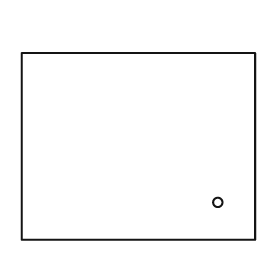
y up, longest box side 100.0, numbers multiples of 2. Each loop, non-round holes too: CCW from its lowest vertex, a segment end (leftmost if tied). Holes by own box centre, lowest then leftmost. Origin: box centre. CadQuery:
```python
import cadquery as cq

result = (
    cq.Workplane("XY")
    .moveTo(-50.0, -40.0)
    .lineTo(50.0, -40.0)
    .lineTo(50.0, 40.0)
    .lineTo(-50.0, 40.0)
    .close()
    .moveTo(34.0, -24.0)
    .circle(2.0)
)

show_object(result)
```